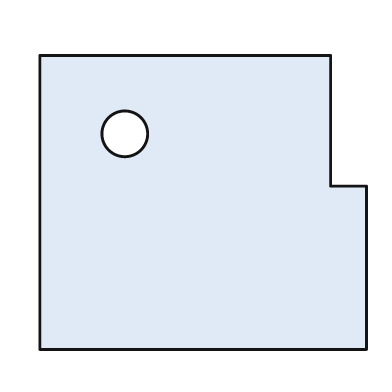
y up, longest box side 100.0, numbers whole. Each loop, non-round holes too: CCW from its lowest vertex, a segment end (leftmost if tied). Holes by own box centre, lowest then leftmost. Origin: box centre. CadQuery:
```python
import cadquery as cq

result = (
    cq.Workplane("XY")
    .moveTo(-50.0, -45.0)
    .lineTo(50.0, -45.0)
    .lineTo(50.0, 5.0)
    .lineTo(39.0, 5.0)
    .lineTo(39.0, 45.0)
    .lineTo(-50.0, 45.0)
    .close()
    .moveTo(-24.0, 21.0)
    .circle(7.0)
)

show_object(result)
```